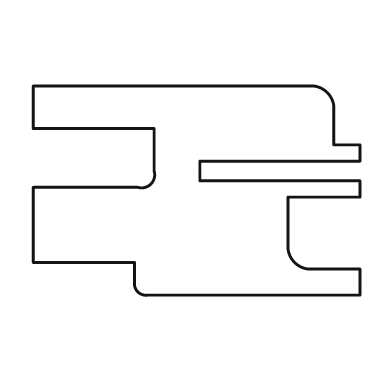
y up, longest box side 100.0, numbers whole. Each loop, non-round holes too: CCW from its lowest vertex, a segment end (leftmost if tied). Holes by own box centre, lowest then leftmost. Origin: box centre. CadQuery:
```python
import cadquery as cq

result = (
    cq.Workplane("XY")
    .moveTo(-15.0, -32.0)
    .lineTo(50.0, -32.0)
    .lineTo(50.0, -24.0)
    .lineTo(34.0, -24.0)
    .threePointArc((30.0, -22.0), (28.0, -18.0))
    .lineTo(28.0, -2.0)
    .lineTo(50.0, -2.0)
    .lineTo(50.0, 3.0)
    .lineTo(1.0, 3.0)
    .lineTo(1.0, 9.0)
    .lineTo(50.0, 9.0)
    .lineTo(50.0, 14.0)
    .lineTo(42.0, 14.0)
    .lineTo(42.0, 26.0)
    .threePointArc((40.0, 30.0), (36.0, 32.0))
    .lineTo(-50.0, 32.0)
    .lineTo(-50.0, 19.0)
    .lineTo(-13.0, 19.0)
    .lineTo(-13.0, 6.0)
    .threePointArc((-14.0, 2.0), (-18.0, 1.0))
    .lineTo(-50.0, 1.0)
    .lineTo(-50.0, -22.0)
    .lineTo(-19.0, -22.0)
    .lineTo(-19.0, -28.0)
    .threePointArc((-18.0, -31.0), (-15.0, -32.0))
    .close()
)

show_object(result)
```